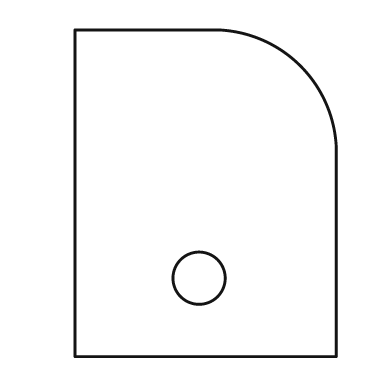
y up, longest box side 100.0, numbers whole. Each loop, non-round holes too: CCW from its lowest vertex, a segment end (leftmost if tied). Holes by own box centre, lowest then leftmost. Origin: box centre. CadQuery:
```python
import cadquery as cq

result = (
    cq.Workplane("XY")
    .moveTo(-40.0, -50.0)
    .lineTo(40.0, -50.0)
    .lineTo(40.0, 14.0)
    .threePointArc((29.0, 39.0), (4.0, 50.0))
    .lineTo(-40.0, 50.0)
    .close()
    .moveTo(-2.0, -26.0)
    .circle(8.0)
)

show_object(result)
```